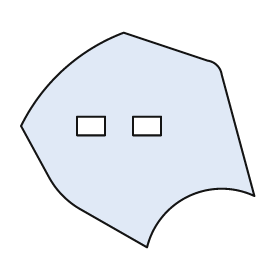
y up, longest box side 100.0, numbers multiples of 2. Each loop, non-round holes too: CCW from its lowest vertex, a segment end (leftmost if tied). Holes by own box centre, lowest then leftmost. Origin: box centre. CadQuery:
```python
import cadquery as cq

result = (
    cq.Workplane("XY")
    .moveTo(4.0, -46.0)
    .threePointArc((22.0, -24.0), (50.0, -24.0))
    .lineTo(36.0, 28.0)
    .threePointArc((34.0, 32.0), (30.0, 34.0))
    .lineTo(-6.0, 46.0)
    .threePointArc((-32.0, 30.0), (-50.0, 6.0))
    .lineTo(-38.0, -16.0)
    .threePointArc((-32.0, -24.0), (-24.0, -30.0))
    .close()
    .moveTo(-26.0, 2.0)
    .lineTo(-14.0, 2.0)
    .lineTo(-14.0, 10.0)
    .lineTo(-26.0, 10.0)
    .close()
    .moveTo(-2.0, 2.0)
    .lineTo(10.0, 2.0)
    .lineTo(10.0, 10.0)
    .lineTo(-2.0, 10.0)
    .close()
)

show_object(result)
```